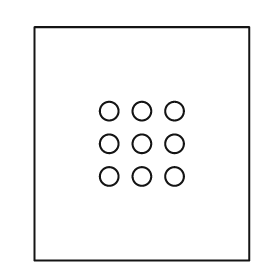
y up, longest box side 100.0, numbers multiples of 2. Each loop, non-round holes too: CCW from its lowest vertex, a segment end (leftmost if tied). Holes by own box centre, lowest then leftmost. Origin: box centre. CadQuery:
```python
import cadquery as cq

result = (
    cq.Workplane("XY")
    .moveTo(-46.0, -50.0)
    .lineTo(46.0, -50.0)
    .lineTo(46.0, 50.0)
    .lineTo(-46.0, 50.0)
    .close()
    .moveTo(-14.0, -14.0)
    .circle(4.0)
    .moveTo(0.0, -14.0)
    .circle(4.0)
    .moveTo(14.0, -14.0)
    .circle(4.0)
    .moveTo(-14.0, 0.0)
    .circle(4.0)
    .moveTo(0.0, 0.0)
    .circle(4.0)
    .moveTo(14.0, 0.0)
    .circle(4.0)
    .moveTo(-14.0, 14.0)
    .circle(4.0)
    .moveTo(0.0, 14.0)
    .circle(4.0)
    .moveTo(14.0, 14.0)
    .circle(4.0)
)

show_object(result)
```